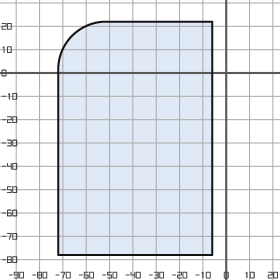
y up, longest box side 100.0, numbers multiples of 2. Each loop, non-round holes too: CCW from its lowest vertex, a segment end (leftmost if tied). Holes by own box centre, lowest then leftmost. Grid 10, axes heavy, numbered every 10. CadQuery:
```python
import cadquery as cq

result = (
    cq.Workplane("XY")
    .moveTo(-72.0, -78.0)
    .lineTo(-6.0, -78.0)
    .lineTo(-6.0, 22.0)
    .lineTo(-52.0, 22.0)
    .threePointArc((-66.0, 16.0), (-72.0, 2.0))
    .close()
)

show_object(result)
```